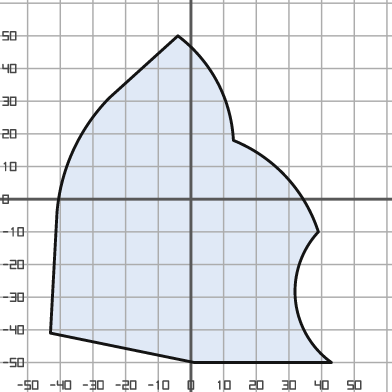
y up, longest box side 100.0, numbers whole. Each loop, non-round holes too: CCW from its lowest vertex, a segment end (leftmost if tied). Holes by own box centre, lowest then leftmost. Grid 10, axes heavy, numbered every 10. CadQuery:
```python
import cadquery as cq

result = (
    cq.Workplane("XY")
    .moveTo(1.0, -50.0)
    .lineTo(43.0, -50.0)
    .threePointArc((32.0, -31.0), (39.0, -10.0))
    .threePointArc((29.0, 7.0), (13.0, 18.0))
    .threePointArc((8.0, 36.0), (-4.0, 50.0))
    .lineTo(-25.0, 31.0)
    .threePointArc((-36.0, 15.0), (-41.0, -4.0))
    .lineTo(-43.0, -41.0)
    .close()
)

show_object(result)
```